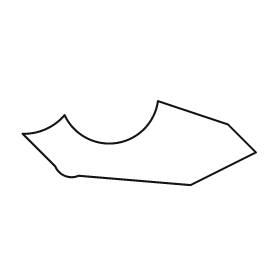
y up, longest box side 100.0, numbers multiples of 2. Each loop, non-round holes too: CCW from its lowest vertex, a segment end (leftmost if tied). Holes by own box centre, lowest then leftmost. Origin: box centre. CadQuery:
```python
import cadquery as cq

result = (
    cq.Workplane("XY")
    .moveTo(22.0, -18.0)
    .lineTo(50.0, -4.0)
    .lineTo(38.0, 8.0)
    .lineTo(8.0, 18.0)
    .threePointArc((-10.0, 0.0), (-32.0, 12.0))
    .threePointArc((-40.0, 6.0), (-50.0, 4.0))
    .lineTo(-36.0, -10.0)
    .threePointArc((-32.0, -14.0), (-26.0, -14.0))
    .close()
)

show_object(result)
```